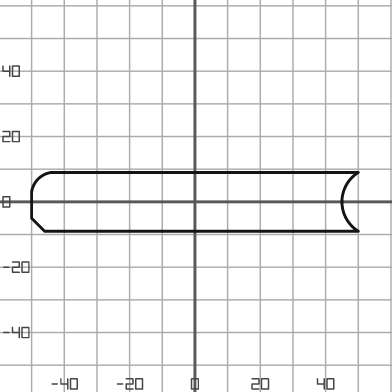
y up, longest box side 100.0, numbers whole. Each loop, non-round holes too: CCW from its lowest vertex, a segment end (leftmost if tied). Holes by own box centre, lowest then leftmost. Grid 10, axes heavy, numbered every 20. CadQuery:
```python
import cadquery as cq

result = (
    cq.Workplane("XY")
    .moveTo(-46.0, -9.0)
    .lineTo(50.0, -9.0)
    .threePointArc((45.0, 0.0), (50.0, 9.0))
    .lineTo(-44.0, 9.0)
    .threePointArc((-48.0, 7.0), (-50.0, 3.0))
    .lineTo(-50.0, -5.0)
    .close()
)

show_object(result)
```